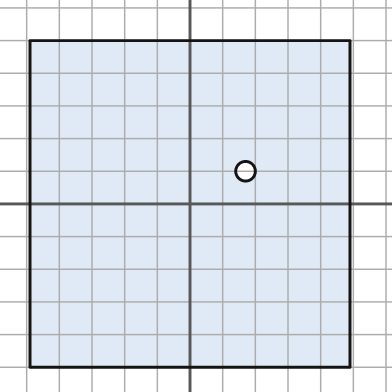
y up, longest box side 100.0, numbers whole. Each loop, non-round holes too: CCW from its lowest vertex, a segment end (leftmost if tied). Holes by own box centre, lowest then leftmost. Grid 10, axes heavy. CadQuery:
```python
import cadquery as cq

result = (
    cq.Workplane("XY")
    .moveTo(-49.0, -50.0)
    .lineTo(49.0, -50.0)
    .lineTo(49.0, 50.0)
    .lineTo(-49.0, 50.0)
    .close()
    .moveTo(17.0, 10.0)
    .circle(3.0)
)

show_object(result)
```